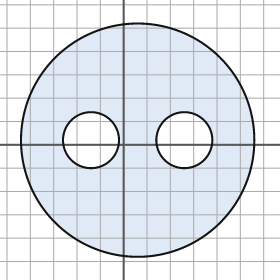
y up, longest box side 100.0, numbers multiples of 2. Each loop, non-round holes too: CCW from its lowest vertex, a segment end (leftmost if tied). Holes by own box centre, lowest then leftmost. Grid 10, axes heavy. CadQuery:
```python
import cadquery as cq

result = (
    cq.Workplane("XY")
    .moveTo(6.0, 2.0)
    .circle(50.0)
    .moveTo(-14.0, 2.0)
    .circle(12.0)
    .moveTo(26.0, 2.0)
    .circle(12.0)
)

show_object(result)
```